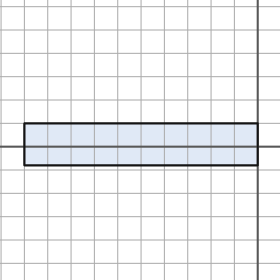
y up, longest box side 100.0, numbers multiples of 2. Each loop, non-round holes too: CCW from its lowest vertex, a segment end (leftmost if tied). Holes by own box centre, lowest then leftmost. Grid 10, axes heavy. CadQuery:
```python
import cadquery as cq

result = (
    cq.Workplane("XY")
    .moveTo(-100.0, -8.0)
    .lineTo(0.0, -8.0)
    .lineTo(0.0, 10.0)
    .lineTo(-100.0, 10.0)
    .close()
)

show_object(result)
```